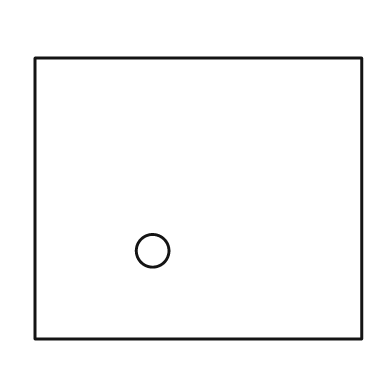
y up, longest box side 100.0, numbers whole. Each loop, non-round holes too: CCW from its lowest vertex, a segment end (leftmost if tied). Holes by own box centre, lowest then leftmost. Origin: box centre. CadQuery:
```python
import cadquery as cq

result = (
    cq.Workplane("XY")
    .moveTo(-50.0, -43.0)
    .lineTo(50.0, -43.0)
    .lineTo(50.0, 43.0)
    .lineTo(-50.0, 43.0)
    .close()
    .moveTo(-14.0, -16.0)
    .circle(5.0)
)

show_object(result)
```